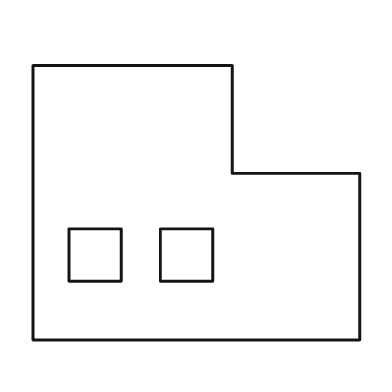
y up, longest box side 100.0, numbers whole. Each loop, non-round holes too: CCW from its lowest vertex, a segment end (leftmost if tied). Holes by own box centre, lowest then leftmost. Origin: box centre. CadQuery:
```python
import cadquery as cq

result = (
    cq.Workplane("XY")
    .moveTo(-50.0, -42.0)
    .lineTo(50.0, -42.0)
    .lineTo(50.0, 9.0)
    .lineTo(11.0, 9.0)
    .lineTo(11.0, 42.0)
    .lineTo(-50.0, 42.0)
    .close()
    .moveTo(-39.0, -24.0)
    .lineTo(-23.0, -24.0)
    .lineTo(-23.0, -8.0)
    .lineTo(-39.0, -8.0)
    .close()
    .moveTo(-11.0, -24.0)
    .lineTo(5.0, -24.0)
    .lineTo(5.0, -8.0)
    .lineTo(-11.0, -8.0)
    .close()
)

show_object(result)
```